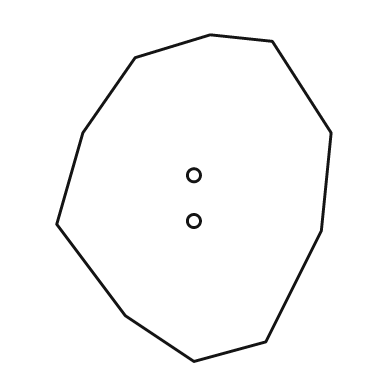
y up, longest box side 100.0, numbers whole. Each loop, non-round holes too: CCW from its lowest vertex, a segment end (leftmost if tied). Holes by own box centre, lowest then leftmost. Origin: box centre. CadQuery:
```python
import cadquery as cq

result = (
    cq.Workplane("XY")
    .moveTo(0.0, -50.0)
    .lineTo(22.0, -44.0)
    .lineTo(39.0, -10.0)
    .lineTo(42.0, 20.0)
    .lineTo(24.0, 48.0)
    .lineTo(5.0, 50.0)
    .lineTo(-18.0, 43.0)
    .lineTo(-34.0, 20.0)
    .lineTo(-42.0, -8.0)
    .lineTo(-21.0, -36.0)
    .close()
    .moveTo(0.0, -7.0)
    .circle(2.0)
    .moveTo(0.0, 7.0)
    .circle(2.0)
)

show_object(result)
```